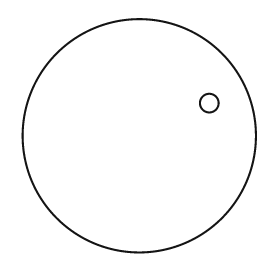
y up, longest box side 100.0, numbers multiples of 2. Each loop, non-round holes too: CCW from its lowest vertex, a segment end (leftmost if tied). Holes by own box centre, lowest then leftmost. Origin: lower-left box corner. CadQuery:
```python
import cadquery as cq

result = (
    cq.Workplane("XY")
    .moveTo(50.0, 50.0)
    .circle(50.0)
    .moveTo(80.0, 64.0)
    .circle(4.0)
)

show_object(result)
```